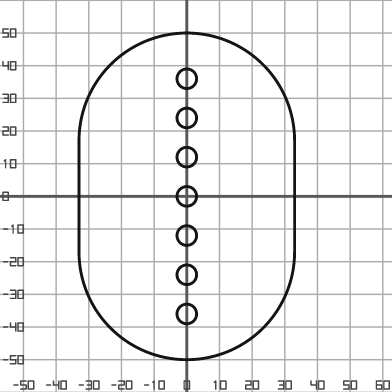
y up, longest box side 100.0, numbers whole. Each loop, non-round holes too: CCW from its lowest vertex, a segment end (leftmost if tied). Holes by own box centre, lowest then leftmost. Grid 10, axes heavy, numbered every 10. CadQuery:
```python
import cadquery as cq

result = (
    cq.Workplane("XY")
    .moveTo(-33.0, -17.0)
    .threePointArc((0.0, -50.0), (33.0, -17.0))
    .lineTo(33.0, 17.0)
    .threePointArc((0.0, 50.0), (-33.0, 17.0))
    .close()
    .moveTo(0.0, -36.0)
    .circle(3.0)
    .moveTo(0.0, -24.0)
    .circle(3.0)
    .moveTo(0.0, -12.0)
    .circle(3.0)
    .moveTo(0.0, 0.0)
    .circle(3.0)
    .moveTo(0.0, 12.0)
    .circle(3.0)
    .moveTo(0.0, 24.0)
    .circle(3.0)
    .moveTo(0.0, 36.0)
    .circle(3.0)
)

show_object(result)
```